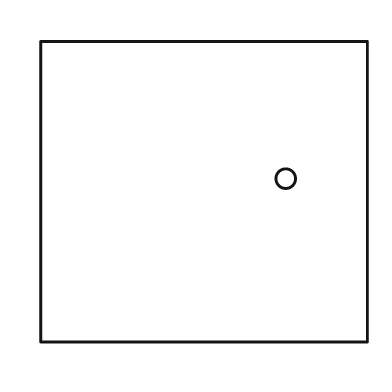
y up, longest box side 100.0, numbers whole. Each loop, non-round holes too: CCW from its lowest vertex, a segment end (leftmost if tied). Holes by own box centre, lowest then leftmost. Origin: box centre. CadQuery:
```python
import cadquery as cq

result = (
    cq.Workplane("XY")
    .moveTo(-50.0, -46.0)
    .lineTo(50.0, -46.0)
    .lineTo(50.0, 46.0)
    .lineTo(-50.0, 46.0)
    .close()
    .moveTo(25.0, 4.0)
    .circle(3.0)
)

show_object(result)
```